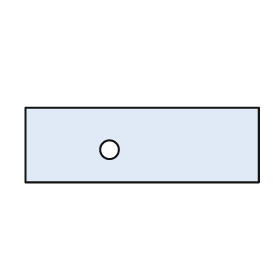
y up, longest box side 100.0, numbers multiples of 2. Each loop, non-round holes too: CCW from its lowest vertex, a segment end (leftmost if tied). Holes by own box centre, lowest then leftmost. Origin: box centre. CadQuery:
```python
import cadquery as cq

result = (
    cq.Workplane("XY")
    .moveTo(-50.0, -16.0)
    .lineTo(50.0, -16.0)
    .lineTo(50.0, 16.0)
    .lineTo(-50.0, 16.0)
    .close()
    .moveTo(-14.0, -2.0)
    .circle(4.0)
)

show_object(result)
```